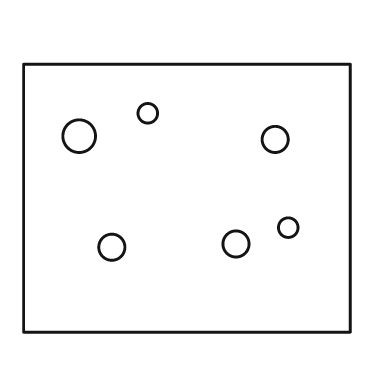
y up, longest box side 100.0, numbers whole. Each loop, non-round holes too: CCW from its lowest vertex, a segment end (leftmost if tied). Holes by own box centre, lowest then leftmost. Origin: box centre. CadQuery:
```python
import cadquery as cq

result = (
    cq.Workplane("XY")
    .moveTo(-50.0, -41.0)
    .lineTo(50.0, -41.0)
    .lineTo(50.0, 41.0)
    .lineTo(-50.0, 41.0)
    .close()
    .moveTo(-23.0, -15.0)
    .circle(4.0)
    .moveTo(15.0, -14.0)
    .circle(4.0)
    .moveTo(31.0, -9.0)
    .circle(3.0)
    .moveTo(27.0, 18.0)
    .circle(4.0)
    .moveTo(-33.0, 19.0)
    .circle(5.0)
    .moveTo(-12.0, 26.0)
    .circle(3.0)
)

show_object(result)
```